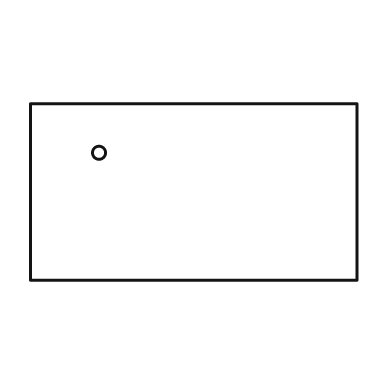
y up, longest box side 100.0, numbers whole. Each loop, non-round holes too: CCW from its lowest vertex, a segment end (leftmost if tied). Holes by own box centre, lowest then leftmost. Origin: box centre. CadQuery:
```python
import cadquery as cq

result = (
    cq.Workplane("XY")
    .moveTo(-50.0, -27.0)
    .lineTo(50.0, -27.0)
    .lineTo(50.0, 27.0)
    .lineTo(-50.0, 27.0)
    .close()
    .moveTo(-29.0, 12.0)
    .circle(2.0)
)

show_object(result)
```